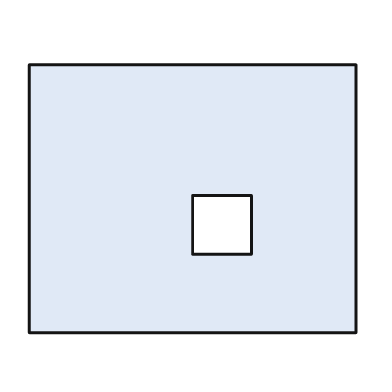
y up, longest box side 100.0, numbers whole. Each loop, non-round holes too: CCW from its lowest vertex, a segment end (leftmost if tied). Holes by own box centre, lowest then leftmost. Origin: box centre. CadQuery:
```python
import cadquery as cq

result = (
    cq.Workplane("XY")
    .moveTo(-50.0, -41.0)
    .lineTo(50.0, -41.0)
    .lineTo(50.0, 41.0)
    .lineTo(-50.0, 41.0)
    .close()
    .moveTo(0.0, -17.0)
    .lineTo(18.0, -17.0)
    .lineTo(18.0, 1.0)
    .lineTo(0.0, 1.0)
    .close()
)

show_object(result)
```